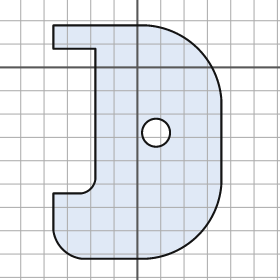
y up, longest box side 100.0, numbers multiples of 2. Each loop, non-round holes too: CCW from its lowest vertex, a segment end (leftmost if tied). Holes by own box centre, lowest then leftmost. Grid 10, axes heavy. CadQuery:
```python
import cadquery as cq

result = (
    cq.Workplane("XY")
    .moveTo(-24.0, -82.0)
    .lineTo(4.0, -82.0)
    .threePointArc((26.0, -72.0), (36.0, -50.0))
    .lineTo(36.0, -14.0)
    .threePointArc((26.0, 8.0), (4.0, 18.0))
    .lineTo(-36.0, 18.0)
    .lineTo(-36.0, 8.0)
    .lineTo(-18.0, 8.0)
    .lineTo(-18.0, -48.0)
    .threePointArc((-20.0, -52.0), (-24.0, -54.0))
    .lineTo(-36.0, -54.0)
    .lineTo(-36.0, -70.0)
    .threePointArc((-32.0, -78.0), (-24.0, -82.0))
    .close()
    .moveTo(8.0, -28.0)
    .circle(6.0)
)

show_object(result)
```